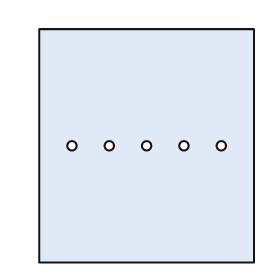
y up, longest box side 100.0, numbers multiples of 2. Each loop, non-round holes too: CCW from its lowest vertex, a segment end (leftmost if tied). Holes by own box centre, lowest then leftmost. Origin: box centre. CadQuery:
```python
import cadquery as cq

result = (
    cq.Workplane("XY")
    .moveTo(-46.0, -50.0)
    .lineTo(46.0, -50.0)
    .lineTo(46.0, 50.0)
    .lineTo(-46.0, 50.0)
    .close()
    .moveTo(-32.0, 0.0)
    .circle(2.0)
    .moveTo(-16.0, 0.0)
    .circle(2.0)
    .moveTo(0.0, 0.0)
    .circle(2.0)
    .moveTo(16.0, 0.0)
    .circle(2.0)
    .moveTo(32.0, 0.0)
    .circle(2.0)
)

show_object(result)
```